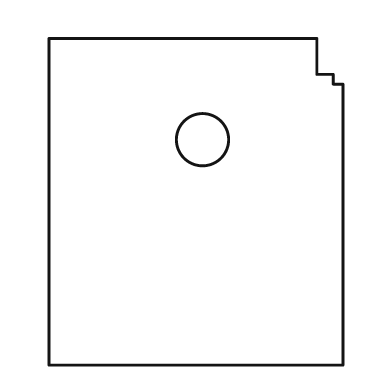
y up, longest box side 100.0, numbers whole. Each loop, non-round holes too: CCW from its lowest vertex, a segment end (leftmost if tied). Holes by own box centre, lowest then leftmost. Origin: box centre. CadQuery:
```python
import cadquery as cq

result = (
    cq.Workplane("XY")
    .moveTo(-45.0, -50.0)
    .lineTo(45.0, -50.0)
    .lineTo(45.0, 36.0)
    .lineTo(42.0, 36.0)
    .lineTo(42.0, 39.0)
    .lineTo(37.0, 39.0)
    .lineTo(37.0, 50.0)
    .lineTo(-45.0, 50.0)
    .close()
    .moveTo(2.0, 19.0)
    .circle(8.0)
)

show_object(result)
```